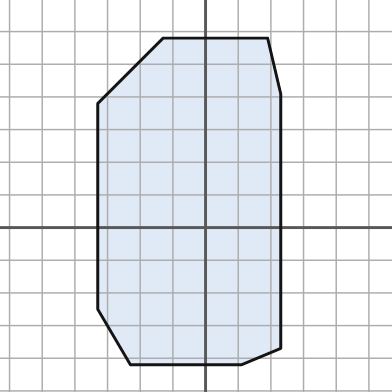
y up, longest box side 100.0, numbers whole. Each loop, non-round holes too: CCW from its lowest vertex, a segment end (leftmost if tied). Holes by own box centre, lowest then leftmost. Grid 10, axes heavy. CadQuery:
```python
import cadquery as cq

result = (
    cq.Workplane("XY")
    .moveTo(-23.0, -42.0)
    .lineTo(11.0, -42.0)
    .lineTo(23.0, -37.0)
    .lineTo(23.0, 41.0)
    .lineTo(19.0, 58.0)
    .lineTo(-13.0, 58.0)
    .lineTo(-33.0, 38.0)
    .lineTo(-33.0, -25.0)
    .close()
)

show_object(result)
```